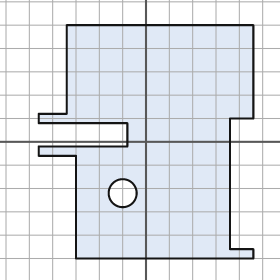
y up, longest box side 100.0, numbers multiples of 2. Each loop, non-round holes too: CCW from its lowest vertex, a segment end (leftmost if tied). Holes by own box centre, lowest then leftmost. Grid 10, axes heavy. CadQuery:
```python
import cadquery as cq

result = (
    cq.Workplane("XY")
    .moveTo(-30.0, -50.0)
    .lineTo(46.0, -50.0)
    .lineTo(46.0, -46.0)
    .lineTo(36.0, -46.0)
    .lineTo(36.0, 10.0)
    .lineTo(46.0, 10.0)
    .lineTo(46.0, 50.0)
    .lineTo(-34.0, 50.0)
    .lineTo(-34.0, 12.0)
    .lineTo(-46.0, 12.0)
    .lineTo(-46.0, 8.0)
    .lineTo(-8.0, 8.0)
    .lineTo(-8.0, -2.0)
    .lineTo(-46.0, -2.0)
    .lineTo(-46.0, -6.0)
    .lineTo(-30.0, -6.0)
    .close()
    .moveTo(-10.0, -22.0)
    .circle(6.0)
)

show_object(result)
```